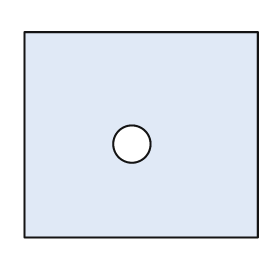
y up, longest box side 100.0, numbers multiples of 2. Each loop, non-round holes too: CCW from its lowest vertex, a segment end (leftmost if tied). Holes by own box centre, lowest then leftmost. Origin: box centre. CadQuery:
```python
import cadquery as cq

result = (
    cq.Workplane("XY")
    .moveTo(-50.0, -44.0)
    .lineTo(50.0, -44.0)
    .lineTo(50.0, 44.0)
    .lineTo(-50.0, 44.0)
    .close()
    .moveTo(-4.0, -4.0)
    .circle(8.0)
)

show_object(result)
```